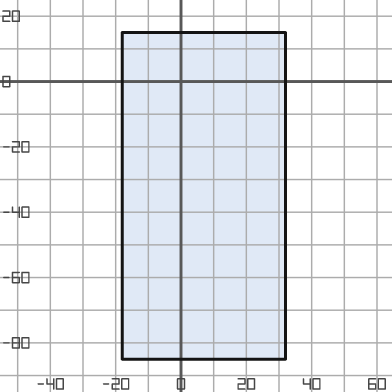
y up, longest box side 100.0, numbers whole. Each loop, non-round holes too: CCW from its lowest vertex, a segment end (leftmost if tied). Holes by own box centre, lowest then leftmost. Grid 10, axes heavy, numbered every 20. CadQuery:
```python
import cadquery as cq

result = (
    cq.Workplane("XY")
    .moveTo(-18.0, -85.0)
    .lineTo(32.0, -85.0)
    .lineTo(32.0, 15.0)
    .lineTo(-18.0, 15.0)
    .close()
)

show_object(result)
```